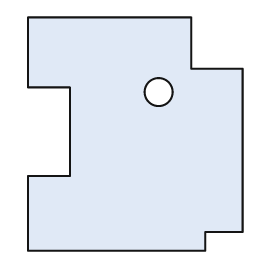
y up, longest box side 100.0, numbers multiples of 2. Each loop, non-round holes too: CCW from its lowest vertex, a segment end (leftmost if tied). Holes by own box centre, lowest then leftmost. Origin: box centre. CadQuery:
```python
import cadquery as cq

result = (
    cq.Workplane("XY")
    .moveTo(-46.0, -50.0)
    .lineTo(30.0, -50.0)
    .lineTo(30.0, -42.0)
    .lineTo(46.0, -42.0)
    .lineTo(46.0, 28.0)
    .lineTo(24.0, 28.0)
    .lineTo(24.0, 50.0)
    .lineTo(-46.0, 50.0)
    .lineTo(-46.0, 20.0)
    .lineTo(-28.0, 20.0)
    .lineTo(-28.0, -18.0)
    .lineTo(-46.0, -18.0)
    .close()
    .moveTo(10.0, 18.0)
    .circle(6.0)
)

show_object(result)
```